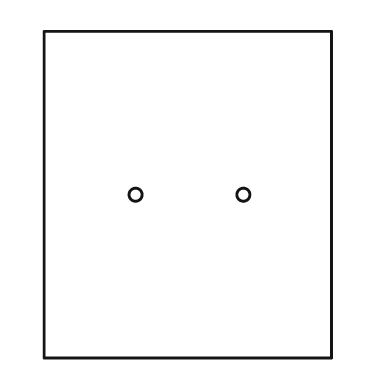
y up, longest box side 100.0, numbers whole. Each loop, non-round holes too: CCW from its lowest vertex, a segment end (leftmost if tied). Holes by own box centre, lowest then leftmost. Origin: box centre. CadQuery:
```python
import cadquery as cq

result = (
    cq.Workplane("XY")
    .moveTo(-44.0, -50.0)
    .lineTo(44.0, -50.0)
    .lineTo(44.0, 50.0)
    .lineTo(-44.0, 50.0)
    .close()
    .moveTo(-16.0, 0.0)
    .circle(2.0)
    .moveTo(17.0, 0.0)
    .circle(2.0)
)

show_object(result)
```